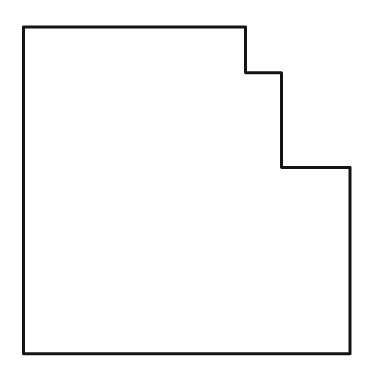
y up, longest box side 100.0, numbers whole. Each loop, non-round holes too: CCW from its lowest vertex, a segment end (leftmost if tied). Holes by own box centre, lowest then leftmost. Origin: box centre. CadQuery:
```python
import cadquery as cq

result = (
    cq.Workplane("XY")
    .moveTo(-50.0, -50.0)
    .lineTo(50.0, -50.0)
    .lineTo(50.0, 7.0)
    .lineTo(29.0, 7.0)
    .lineTo(29.0, 36.0)
    .lineTo(18.0, 36.0)
    .lineTo(18.0, 50.0)
    .lineTo(-50.0, 50.0)
    .close()
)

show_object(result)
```